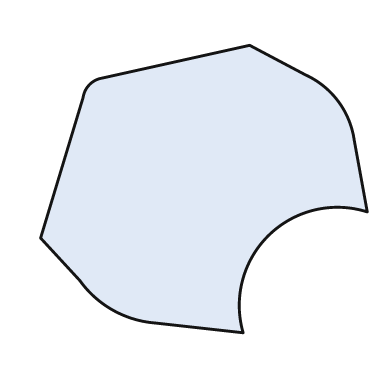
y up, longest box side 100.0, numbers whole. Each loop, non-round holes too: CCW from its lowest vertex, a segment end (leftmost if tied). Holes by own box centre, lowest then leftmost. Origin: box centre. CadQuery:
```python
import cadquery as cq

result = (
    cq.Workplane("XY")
    .moveTo(12.0, -44.0)
    .threePointArc((20.0, -14.0), (50.0, -7.0))
    .lineTo(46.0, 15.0)
    .threePointArc((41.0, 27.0), (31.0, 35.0))
    .lineTo(14.0, 44.0)
    .lineTo(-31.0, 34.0)
    .threePointArc((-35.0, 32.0), (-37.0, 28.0))
    .lineTo(-50.0, -15.0)
    .lineTo(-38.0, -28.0)
    .threePointArc((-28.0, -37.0), (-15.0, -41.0))
    .close()
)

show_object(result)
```